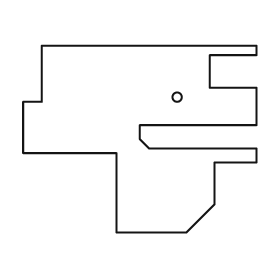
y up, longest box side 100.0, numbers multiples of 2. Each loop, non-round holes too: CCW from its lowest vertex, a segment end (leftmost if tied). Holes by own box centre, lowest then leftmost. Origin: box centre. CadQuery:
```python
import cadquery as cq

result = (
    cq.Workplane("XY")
    .moveTo(-10.0, -40.0)
    .lineTo(20.0, -40.0)
    .lineTo(32.0, -28.0)
    .lineTo(32.0, -10.0)
    .lineTo(50.0, -10.0)
    .lineTo(50.0, -4.0)
    .lineTo(4.0, -4.0)
    .lineTo(0.0, 0.0)
    .lineTo(0.0, 6.0)
    .lineTo(50.0, 6.0)
    .lineTo(50.0, 22.0)
    .lineTo(30.0, 22.0)
    .lineTo(30.0, 36.0)
    .lineTo(50.0, 36.0)
    .lineTo(50.0, 40.0)
    .lineTo(-42.0, 40.0)
    .lineTo(-42.0, 16.0)
    .lineTo(-50.0, 16.0)
    .lineTo(-50.0, -6.0)
    .lineTo(-10.0, -6.0)
    .close()
    .moveTo(16.0, 18.0)
    .circle(2.0)
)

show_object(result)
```